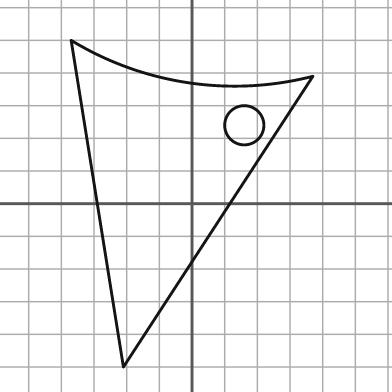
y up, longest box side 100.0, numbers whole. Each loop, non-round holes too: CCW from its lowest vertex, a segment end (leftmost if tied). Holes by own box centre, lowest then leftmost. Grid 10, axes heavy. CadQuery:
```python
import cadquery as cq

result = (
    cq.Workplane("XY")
    .moveTo(-21.0, -50.0)
    .lineTo(37.0, 39.0)
    .threePointArc((-1.0, 37.0), (-37.0, 50.0))
    .close()
    .moveTo(16.0, 24.0)
    .circle(6.0)
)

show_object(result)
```